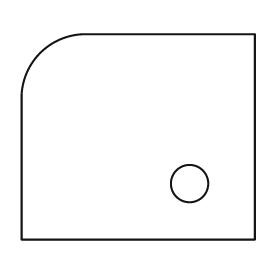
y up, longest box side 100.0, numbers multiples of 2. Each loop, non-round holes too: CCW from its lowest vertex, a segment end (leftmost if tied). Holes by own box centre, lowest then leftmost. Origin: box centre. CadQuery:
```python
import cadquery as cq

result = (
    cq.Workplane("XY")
    .moveTo(-50.0, -44.0)
    .lineTo(50.0, -44.0)
    .lineTo(50.0, 44.0)
    .lineTo(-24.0, 44.0)
    .threePointArc((-42.0, 36.0), (-50.0, 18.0))
    .close()
    .moveTo(22.0, -20.0)
    .circle(8.0)
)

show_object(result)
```